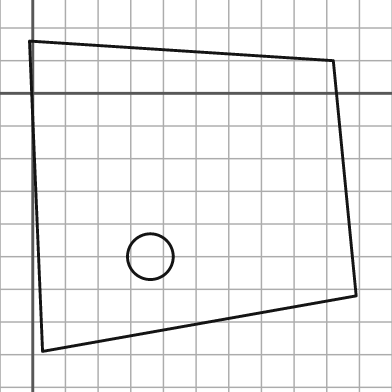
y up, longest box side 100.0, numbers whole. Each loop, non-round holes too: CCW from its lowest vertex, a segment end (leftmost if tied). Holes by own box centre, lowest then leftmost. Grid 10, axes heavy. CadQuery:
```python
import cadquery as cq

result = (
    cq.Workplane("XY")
    .moveTo(3.0, -79.0)
    .lineTo(99.0, -62.0)
    .lineTo(92.0, 10.0)
    .lineTo(-1.0, 16.0)
    .close()
    .moveTo(36.0, -50.0)
    .circle(7.0)
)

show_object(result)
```